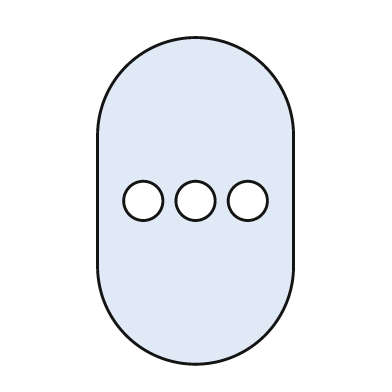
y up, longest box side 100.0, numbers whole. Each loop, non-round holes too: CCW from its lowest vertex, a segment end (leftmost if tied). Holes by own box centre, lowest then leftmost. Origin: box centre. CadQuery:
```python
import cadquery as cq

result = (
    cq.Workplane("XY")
    .moveTo(-30.0, -20.0)
    .threePointArc((0.0, -50.0), (30.0, -20.0))
    .lineTo(30.0, 20.0)
    .threePointArc((0.0, 50.0), (-30.0, 20.0))
    .close()
    .moveTo(-16.0, 0.0)
    .circle(6.0)
    .moveTo(0.0, 0.0)
    .circle(6.0)
    .moveTo(16.0, 0.0)
    .circle(6.0)
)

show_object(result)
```